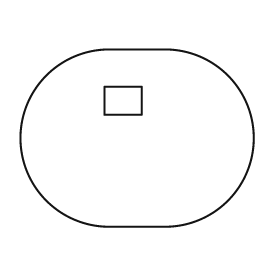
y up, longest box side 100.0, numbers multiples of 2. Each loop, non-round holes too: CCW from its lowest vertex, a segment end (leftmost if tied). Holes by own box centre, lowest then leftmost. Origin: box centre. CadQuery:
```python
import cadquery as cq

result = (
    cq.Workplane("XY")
    .moveTo(-12.0, -38.0)
    .lineTo(12.0, -38.0)
    .threePointArc((50.0, 0.0), (12.0, 38.0))
    .lineTo(-12.0, 38.0)
    .threePointArc((-50.0, 0.0), (-12.0, -38.0))
    .close()
    .moveTo(-14.0, 10.0)
    .lineTo(2.0, 10.0)
    .lineTo(2.0, 22.0)
    .lineTo(-14.0, 22.0)
    .close()
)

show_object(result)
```